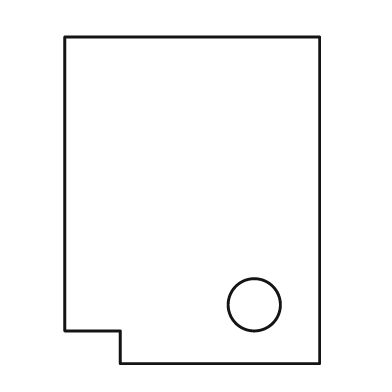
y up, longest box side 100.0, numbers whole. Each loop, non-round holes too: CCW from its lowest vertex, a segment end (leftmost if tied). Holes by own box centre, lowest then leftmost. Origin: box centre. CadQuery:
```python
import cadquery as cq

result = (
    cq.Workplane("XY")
    .moveTo(-22.0, -50.0)
    .lineTo(39.0, -50.0)
    .lineTo(39.0, 50.0)
    .lineTo(-39.0, 50.0)
    .lineTo(-39.0, -40.0)
    .lineTo(-22.0, -40.0)
    .close()
    .moveTo(19.0, -32.0)
    .circle(8.0)
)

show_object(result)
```